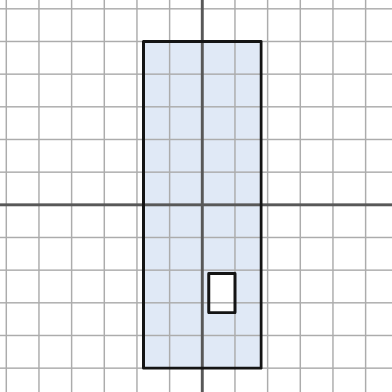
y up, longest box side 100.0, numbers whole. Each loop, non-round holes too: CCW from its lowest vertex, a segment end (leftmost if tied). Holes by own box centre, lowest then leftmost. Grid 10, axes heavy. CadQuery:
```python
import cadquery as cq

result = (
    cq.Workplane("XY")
    .moveTo(-18.0, -50.0)
    .lineTo(18.0, -50.0)
    .lineTo(18.0, 50.0)
    .lineTo(-18.0, 50.0)
    .close()
    .moveTo(2.0, -33.0)
    .lineTo(10.0, -33.0)
    .lineTo(10.0, -21.0)
    .lineTo(2.0, -21.0)
    .close()
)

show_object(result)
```